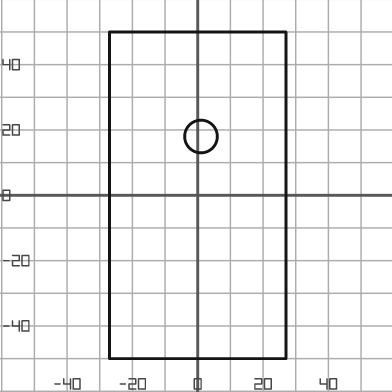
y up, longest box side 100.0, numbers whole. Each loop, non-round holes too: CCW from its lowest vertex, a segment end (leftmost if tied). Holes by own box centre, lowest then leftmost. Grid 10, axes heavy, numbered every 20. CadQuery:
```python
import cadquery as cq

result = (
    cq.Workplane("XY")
    .moveTo(-27.0, -50.0)
    .lineTo(27.0, -50.0)
    .lineTo(27.0, 50.0)
    .lineTo(-27.0, 50.0)
    .close()
    .moveTo(1.0, 18.0)
    .circle(5.0)
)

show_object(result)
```